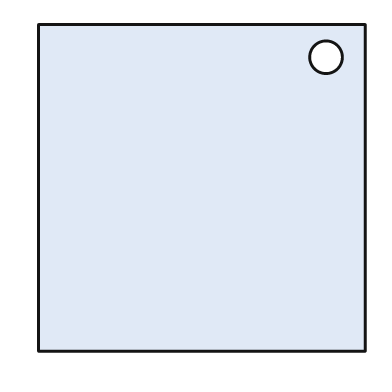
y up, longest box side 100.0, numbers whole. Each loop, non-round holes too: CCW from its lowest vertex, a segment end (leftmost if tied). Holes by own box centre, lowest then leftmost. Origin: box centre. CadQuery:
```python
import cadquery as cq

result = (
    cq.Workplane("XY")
    .moveTo(-50.0, -50.0)
    .lineTo(50.0, -50.0)
    .lineTo(50.0, 50.0)
    .lineTo(-50.0, 50.0)
    .close()
    .moveTo(38.0, 40.0)
    .circle(5.0)
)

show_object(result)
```